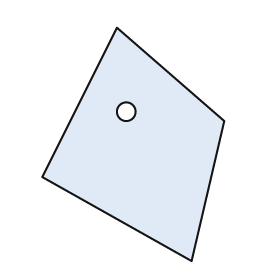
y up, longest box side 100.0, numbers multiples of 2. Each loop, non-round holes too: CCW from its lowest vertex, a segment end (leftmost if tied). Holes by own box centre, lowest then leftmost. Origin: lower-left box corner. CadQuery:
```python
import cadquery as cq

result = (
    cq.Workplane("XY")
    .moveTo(64.0, 0.0)
    .lineTo(78.0, 60.0)
    .lineTo(32.0, 100.0)
    .lineTo(0.0, 36.0)
    .close()
    .moveTo(36.0, 64.0)
    .circle(4.0)
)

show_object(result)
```